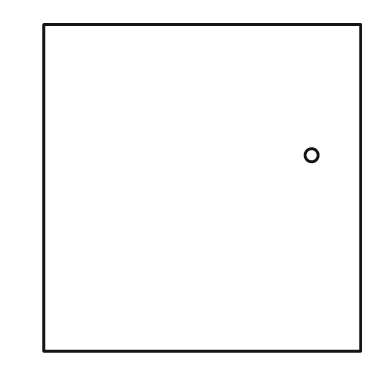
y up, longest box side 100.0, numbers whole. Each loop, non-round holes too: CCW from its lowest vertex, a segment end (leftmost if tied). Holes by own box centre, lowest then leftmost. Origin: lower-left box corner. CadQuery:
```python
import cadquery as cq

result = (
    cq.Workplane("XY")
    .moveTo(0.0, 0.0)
    .lineTo(97.0, 0.0)
    .lineTo(97.0, 100.0)
    .lineTo(0.0, 100.0)
    .close()
    .moveTo(82.0, 60.0)
    .circle(2.0)
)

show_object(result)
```